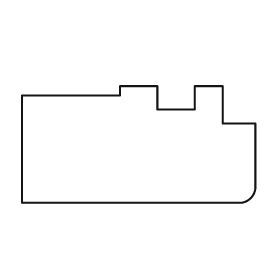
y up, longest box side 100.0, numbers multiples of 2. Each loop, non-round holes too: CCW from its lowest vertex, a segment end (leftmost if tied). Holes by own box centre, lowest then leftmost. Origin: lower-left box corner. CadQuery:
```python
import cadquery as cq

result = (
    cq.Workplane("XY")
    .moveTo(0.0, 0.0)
    .lineTo(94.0, 0.0)
    .threePointArc((98.0, 2.0), (100.0, 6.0))
    .lineTo(100.0, 34.0)
    .lineTo(86.0, 34.0)
    .lineTo(86.0, 50.0)
    .lineTo(74.0, 50.0)
    .lineTo(74.0, 40.0)
    .lineTo(58.0, 40.0)
    .lineTo(58.0, 50.0)
    .lineTo(42.0, 50.0)
    .lineTo(42.0, 46.0)
    .lineTo(0.0, 46.0)
    .close()
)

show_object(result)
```